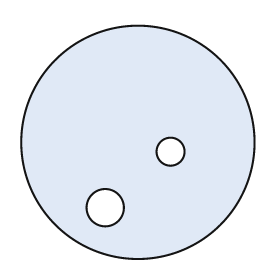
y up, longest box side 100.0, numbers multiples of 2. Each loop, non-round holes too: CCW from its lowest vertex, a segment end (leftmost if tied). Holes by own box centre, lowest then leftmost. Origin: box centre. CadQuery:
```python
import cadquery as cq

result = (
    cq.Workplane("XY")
    .moveTo(0.0, 0.0)
    .circle(50.0)
    .moveTo(-14.0, -28.0)
    .circle(8.0)
    .moveTo(14.0, -4.0)
    .circle(6.0)
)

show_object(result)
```